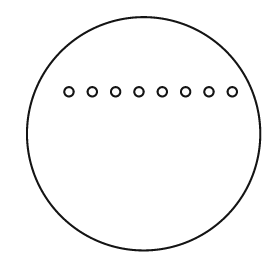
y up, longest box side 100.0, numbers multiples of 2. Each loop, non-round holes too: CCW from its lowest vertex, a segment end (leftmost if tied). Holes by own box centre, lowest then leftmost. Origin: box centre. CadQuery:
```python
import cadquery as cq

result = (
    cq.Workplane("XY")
    .moveTo(0.0, 0.0)
    .circle(50.0)
    .moveTo(-32.0, 18.0)
    .circle(2.0)
    .moveTo(-22.0, 18.0)
    .circle(2.0)
    .moveTo(-12.0, 18.0)
    .circle(2.0)
    .moveTo(-2.0, 18.0)
    .circle(2.0)
    .moveTo(8.0, 18.0)
    .circle(2.0)
    .moveTo(18.0, 18.0)
    .circle(2.0)
    .moveTo(28.0, 18.0)
    .circle(2.0)
    .moveTo(38.0, 18.0)
    .circle(2.0)
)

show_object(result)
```